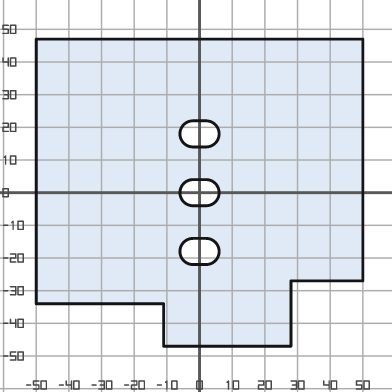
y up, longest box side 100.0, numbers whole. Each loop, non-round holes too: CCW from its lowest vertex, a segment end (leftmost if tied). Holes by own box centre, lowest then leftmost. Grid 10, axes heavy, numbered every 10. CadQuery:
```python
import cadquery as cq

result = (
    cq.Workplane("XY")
    .moveTo(-11.0, -47.0)
    .lineTo(28.0, -47.0)
    .lineTo(28.0, -27.0)
    .lineTo(50.0, -27.0)
    .lineTo(50.0, 47.0)
    .lineTo(-50.0, 47.0)
    .lineTo(-50.0, -34.0)
    .lineTo(-11.0, -34.0)
    .close()
    .moveTo(-2.0, -22.0)
    .lineTo(2.0, -22.0)
    .threePointArc((6.0, -18.0), (2.0, -14.0))
    .lineTo(-2.0, -14.0)
    .threePointArc((-6.0, -18.0), (-2.0, -22.0))
    .close()
    .moveTo(-2.0, -4.0)
    .lineTo(2.0, -4.0)
    .threePointArc((6.0, 0.0), (2.0, 4.0))
    .lineTo(-2.0, 4.0)
    .threePointArc((-6.0, 0.0), (-2.0, -4.0))
    .close()
    .moveTo(-2.0, 14.0)
    .lineTo(2.0, 14.0)
    .threePointArc((6.0, 18.0), (2.0, 22.0))
    .lineTo(-2.0, 22.0)
    .threePointArc((-6.0, 18.0), (-2.0, 14.0))
    .close()
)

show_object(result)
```